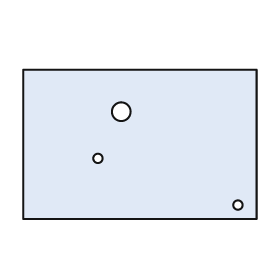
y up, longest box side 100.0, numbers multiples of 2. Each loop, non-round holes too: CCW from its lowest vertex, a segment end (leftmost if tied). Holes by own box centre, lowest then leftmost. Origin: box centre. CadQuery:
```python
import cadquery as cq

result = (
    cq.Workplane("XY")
    .moveTo(-50.0, -32.0)
    .lineTo(50.0, -32.0)
    .lineTo(50.0, 32.0)
    .lineTo(-50.0, 32.0)
    .close()
    .moveTo(42.0, -26.0)
    .circle(2.0)
    .moveTo(-18.0, -6.0)
    .circle(2.0)
    .moveTo(-8.0, 14.0)
    .circle(4.0)
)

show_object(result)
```